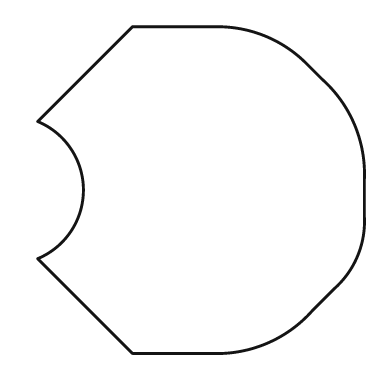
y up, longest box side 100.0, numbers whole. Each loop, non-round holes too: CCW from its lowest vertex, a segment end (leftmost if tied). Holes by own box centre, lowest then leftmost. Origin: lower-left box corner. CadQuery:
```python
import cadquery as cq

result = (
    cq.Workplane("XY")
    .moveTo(29.0, 0.0)
    .lineTo(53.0, 0.0)
    .threePointArc((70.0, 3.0), (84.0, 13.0))
    .lineTo(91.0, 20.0)
    .threePointArc((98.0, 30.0), (100.0, 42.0))
    .lineTo(100.0, 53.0)
    .threePointArc((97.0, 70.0), (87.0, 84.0))
    .lineTo(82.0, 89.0)
    .threePointArc((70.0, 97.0), (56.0, 100.0))
    .lineTo(29.0, 100.0)
    .lineTo(0.0, 71.0)
    .threePointArc((14.0, 50.0), (0.0, 29.0))
    .close()
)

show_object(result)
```